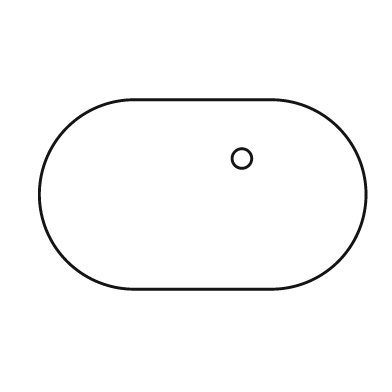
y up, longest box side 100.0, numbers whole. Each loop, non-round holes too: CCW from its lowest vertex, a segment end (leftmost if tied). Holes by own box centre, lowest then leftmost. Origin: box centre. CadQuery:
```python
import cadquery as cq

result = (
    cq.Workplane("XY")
    .moveTo(-21.0, -29.0)
    .lineTo(21.0, -29.0)
    .threePointArc((50.0, 0.0), (21.0, 29.0))
    .lineTo(-21.0, 29.0)
    .threePointArc((-50.0, 0.0), (-21.0, -29.0))
    .close()
    .moveTo(12.0, 11.0)
    .circle(3.0)
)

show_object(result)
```